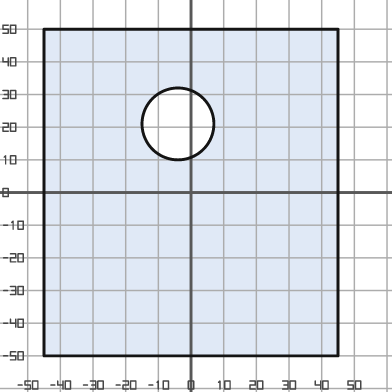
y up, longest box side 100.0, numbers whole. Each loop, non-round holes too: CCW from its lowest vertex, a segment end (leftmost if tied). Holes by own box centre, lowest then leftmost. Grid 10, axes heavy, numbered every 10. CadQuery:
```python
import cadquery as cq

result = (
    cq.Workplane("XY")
    .moveTo(-45.0, -50.0)
    .lineTo(45.0, -50.0)
    .lineTo(45.0, 50.0)
    .lineTo(-45.0, 50.0)
    .close()
    .moveTo(-4.0, 21.0)
    .circle(11.0)
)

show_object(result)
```